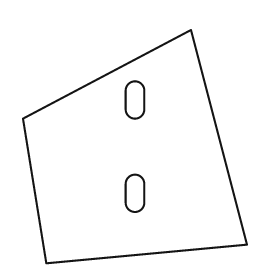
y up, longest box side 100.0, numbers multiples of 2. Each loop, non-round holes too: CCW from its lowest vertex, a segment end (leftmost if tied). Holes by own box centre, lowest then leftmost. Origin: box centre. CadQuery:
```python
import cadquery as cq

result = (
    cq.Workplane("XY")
    .moveTo(-38.0, -50.0)
    .lineTo(48.0, -42.0)
    .lineTo(24.0, 50.0)
    .lineTo(-48.0, 12.0)
    .close()
    .moveTo(-4.0, -24.0)
    .threePointArc((0.0, -28.0), (4.0, -24.0))
    .lineTo(4.0, -16.0)
    .threePointArc((0.0, -12.0), (-4.0, -16.0))
    .close()
    .moveTo(-4.0, 16.0)
    .threePointArc((0.0, 12.0), (4.0, 16.0))
    .lineTo(4.0, 24.0)
    .threePointArc((0.0, 28.0), (-4.0, 24.0))
    .close()
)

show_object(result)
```